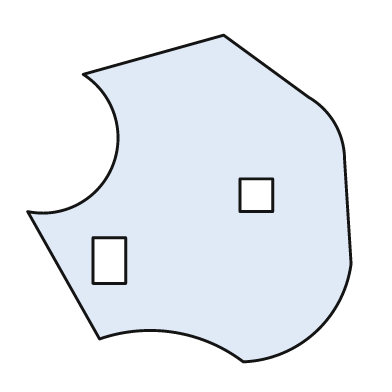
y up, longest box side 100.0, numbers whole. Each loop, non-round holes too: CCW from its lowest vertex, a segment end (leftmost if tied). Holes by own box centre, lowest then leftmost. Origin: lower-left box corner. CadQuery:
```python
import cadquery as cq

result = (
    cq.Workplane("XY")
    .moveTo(66.0, 0.0)
    .threePointArc((88.0, 9.0), (99.0, 30.0))
    .lineTo(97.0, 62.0)
    .threePointArc((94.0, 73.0), (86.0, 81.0))
    .lineTo(60.0, 100.0)
    .lineTo(17.0, 88.0)
    .threePointArc((26.0, 60.0), (0.0, 46.0))
    .lineTo(22.0, 7.0)
    .threePointArc((45.0, 9.0), (66.0, 0.0))
    .close()
    .moveTo(20.0, 24.0)
    .lineTo(30.0, 24.0)
    .lineTo(30.0, 38.0)
    .lineTo(20.0, 38.0)
    .close()
    .moveTo(65.0, 46.0)
    .lineTo(75.0, 46.0)
    .lineTo(75.0, 56.0)
    .lineTo(65.0, 56.0)
    .close()
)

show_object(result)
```